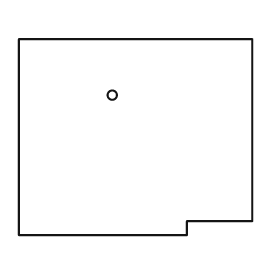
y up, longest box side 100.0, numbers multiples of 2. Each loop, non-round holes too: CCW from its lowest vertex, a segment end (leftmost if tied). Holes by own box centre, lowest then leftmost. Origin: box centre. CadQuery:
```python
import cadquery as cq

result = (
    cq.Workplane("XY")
    .moveTo(-50.0, -42.0)
    .lineTo(22.0, -42.0)
    .lineTo(22.0, -36.0)
    .lineTo(50.0, -36.0)
    .lineTo(50.0, 42.0)
    .lineTo(-50.0, 42.0)
    .close()
    .moveTo(-10.0, 18.0)
    .circle(2.0)
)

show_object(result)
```